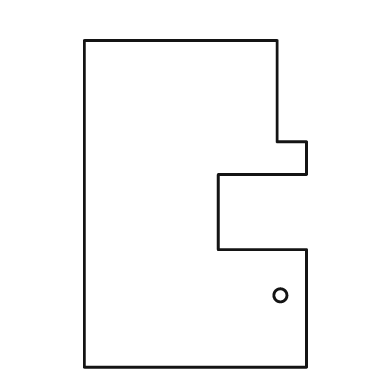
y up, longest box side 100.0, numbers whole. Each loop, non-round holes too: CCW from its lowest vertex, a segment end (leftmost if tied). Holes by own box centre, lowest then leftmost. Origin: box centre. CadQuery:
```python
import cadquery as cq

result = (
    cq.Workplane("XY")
    .moveTo(-34.0, -50.0)
    .lineTo(34.0, -50.0)
    .lineTo(34.0, -14.0)
    .lineTo(7.0, -14.0)
    .lineTo(7.0, 9.0)
    .lineTo(34.0, 9.0)
    .lineTo(34.0, 19.0)
    .lineTo(25.0, 19.0)
    .lineTo(25.0, 50.0)
    .lineTo(-34.0, 50.0)
    .close()
    .moveTo(26.0, -28.0)
    .circle(2.0)
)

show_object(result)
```